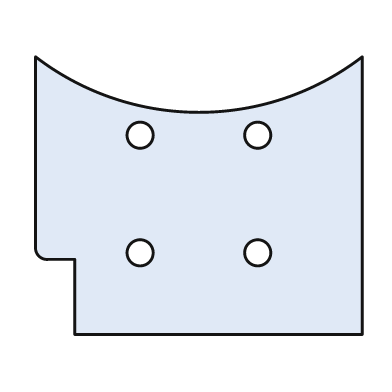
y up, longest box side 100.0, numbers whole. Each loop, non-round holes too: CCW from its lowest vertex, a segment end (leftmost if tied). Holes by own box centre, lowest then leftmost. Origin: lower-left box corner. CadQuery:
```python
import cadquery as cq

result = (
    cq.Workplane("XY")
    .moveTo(12.0, 0.0)
    .lineTo(100.0, 0.0)
    .lineTo(100.0, 85.0)
    .threePointArc((50.0, 68.0), (0.0, 85.0))
    .lineTo(0.0, 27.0)
    .threePointArc((1.0, 24.0), (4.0, 23.0))
    .lineTo(12.0, 23.0)
    .close()
    .moveTo(32.0, 25.0)
    .circle(4.0)
    .moveTo(68.0, 25.0)
    .circle(4.0)
    .moveTo(32.0, 61.0)
    .circle(4.0)
    .moveTo(68.0, 61.0)
    .circle(4.0)
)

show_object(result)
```